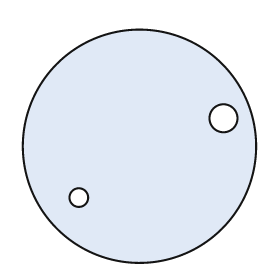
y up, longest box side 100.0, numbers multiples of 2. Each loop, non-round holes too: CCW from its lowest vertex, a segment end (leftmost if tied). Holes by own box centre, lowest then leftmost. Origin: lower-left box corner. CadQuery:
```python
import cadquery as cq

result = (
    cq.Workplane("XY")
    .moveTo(50.0, 50.0)
    .circle(50.0)
    .moveTo(24.0, 28.0)
    .circle(4.0)
    .moveTo(86.0, 62.0)
    .circle(6.0)
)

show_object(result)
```